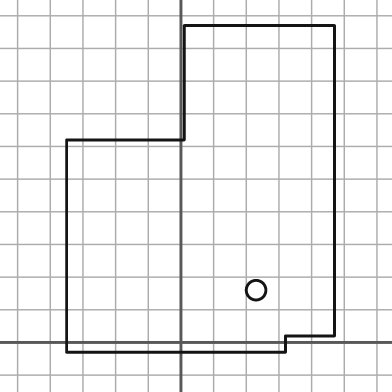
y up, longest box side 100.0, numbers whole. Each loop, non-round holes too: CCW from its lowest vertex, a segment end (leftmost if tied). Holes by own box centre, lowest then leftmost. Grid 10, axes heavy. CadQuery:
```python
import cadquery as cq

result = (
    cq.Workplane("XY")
    .moveTo(-35.0, -3.0)
    .lineTo(32.0, -3.0)
    .lineTo(32.0, 2.0)
    .lineTo(47.0, 2.0)
    .lineTo(47.0, 97.0)
    .lineTo(1.0, 97.0)
    .lineTo(1.0, 62.0)
    .lineTo(-35.0, 62.0)
    .close()
    .moveTo(23.0, 16.0)
    .circle(3.0)
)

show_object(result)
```